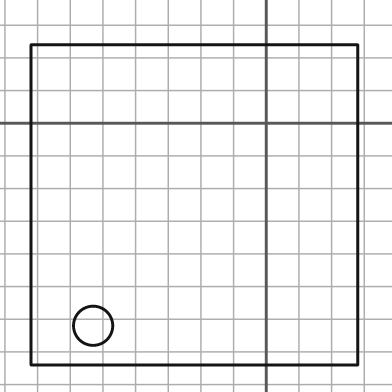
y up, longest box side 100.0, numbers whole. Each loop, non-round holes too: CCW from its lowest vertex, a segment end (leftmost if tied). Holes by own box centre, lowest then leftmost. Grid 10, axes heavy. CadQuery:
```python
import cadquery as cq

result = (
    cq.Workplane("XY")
    .moveTo(-72.0, -74.0)
    .lineTo(28.0, -74.0)
    .lineTo(28.0, 24.0)
    .lineTo(-72.0, 24.0)
    .close()
    .moveTo(-53.0, -62.0)
    .circle(6.0)
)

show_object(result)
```